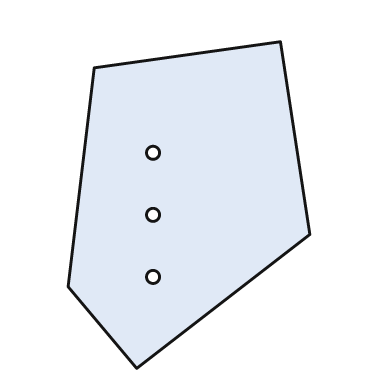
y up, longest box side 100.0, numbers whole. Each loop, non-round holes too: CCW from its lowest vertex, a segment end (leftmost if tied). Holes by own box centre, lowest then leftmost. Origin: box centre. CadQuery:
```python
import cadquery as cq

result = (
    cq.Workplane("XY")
    .moveTo(-16.0, -50.0)
    .lineTo(37.0, -9.0)
    .lineTo(28.0, 50.0)
    .lineTo(-29.0, 42.0)
    .lineTo(-37.0, -25.0)
    .close()
    .moveTo(-11.0, -22.0)
    .circle(2.0)
    .moveTo(-11.0, -3.0)
    .circle(2.0)
    .moveTo(-11.0, 16.0)
    .circle(2.0)
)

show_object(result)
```